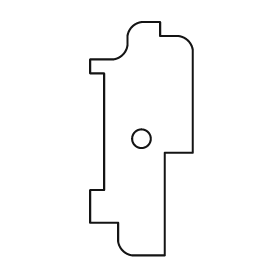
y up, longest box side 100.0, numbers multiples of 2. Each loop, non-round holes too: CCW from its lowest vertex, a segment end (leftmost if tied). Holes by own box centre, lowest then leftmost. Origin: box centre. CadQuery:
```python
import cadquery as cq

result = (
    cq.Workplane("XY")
    .moveTo(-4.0, -50.0)
    .lineTo(10.0, -50.0)
    .lineTo(10.0, -6.0)
    .lineTo(22.0, -6.0)
    .lineTo(22.0, 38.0)
    .threePointArc((20.0, 42.0), (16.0, 44.0))
    .lineTo(8.0, 44.0)
    .lineTo(8.0, 50.0)
    .lineTo(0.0, 50.0)
    .threePointArc((-4.0, 48.0), (-6.0, 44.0))
    .lineTo(-6.0, 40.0)
    .threePointArc((-8.0, 36.0), (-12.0, 34.0))
    .lineTo(-22.0, 34.0)
    .lineTo(-22.0, 28.0)
    .lineTo(-16.0, 28.0)
    .lineTo(-16.0, -22.0)
    .lineTo(-22.0, -22.0)
    .lineTo(-22.0, -36.0)
    .lineTo(-10.0, -36.0)
    .lineTo(-10.0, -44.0)
    .threePointArc((-8.0, -48.0), (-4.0, -50.0))
    .close()
    .moveTo(0.0, 0.0)
    .circle(4.0)
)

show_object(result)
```